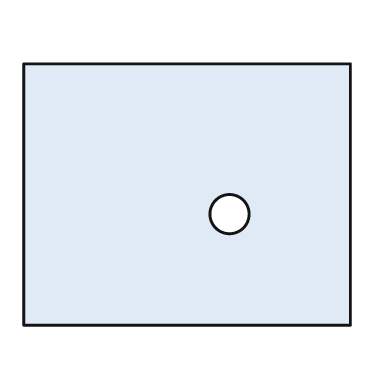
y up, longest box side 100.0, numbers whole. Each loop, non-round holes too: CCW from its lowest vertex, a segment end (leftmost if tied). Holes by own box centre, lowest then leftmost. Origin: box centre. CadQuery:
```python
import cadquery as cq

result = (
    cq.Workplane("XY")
    .moveTo(-50.0, -40.0)
    .lineTo(50.0, -40.0)
    .lineTo(50.0, 40.0)
    .lineTo(-50.0, 40.0)
    .close()
    .moveTo(13.0, -6.0)
    .circle(6.0)
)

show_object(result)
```